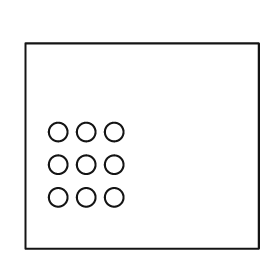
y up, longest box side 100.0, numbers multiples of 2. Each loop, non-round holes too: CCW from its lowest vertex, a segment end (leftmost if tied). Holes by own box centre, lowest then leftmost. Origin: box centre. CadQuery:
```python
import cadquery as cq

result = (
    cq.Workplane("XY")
    .moveTo(-50.0, -44.0)
    .lineTo(50.0, -44.0)
    .lineTo(50.0, 44.0)
    .lineTo(-50.0, 44.0)
    .close()
    .moveTo(-36.0, -22.0)
    .circle(4.0)
    .moveTo(-24.0, -22.0)
    .circle(4.0)
    .moveTo(-12.0, -22.0)
    .circle(4.0)
    .moveTo(-36.0, -8.0)
    .circle(4.0)
    .moveTo(-24.0, -8.0)
    .circle(4.0)
    .moveTo(-12.0, -8.0)
    .circle(4.0)
    .moveTo(-36.0, 6.0)
    .circle(4.0)
    .moveTo(-24.0, 6.0)
    .circle(4.0)
    .moveTo(-12.0, 6.0)
    .circle(4.0)
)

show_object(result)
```